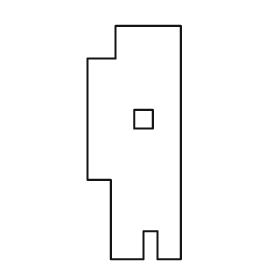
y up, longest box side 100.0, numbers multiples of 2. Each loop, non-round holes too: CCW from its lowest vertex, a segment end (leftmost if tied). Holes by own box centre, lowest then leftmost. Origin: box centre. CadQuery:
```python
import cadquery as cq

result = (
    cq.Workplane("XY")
    .moveTo(-10.0, -50.0)
    .lineTo(4.0, -50.0)
    .lineTo(4.0, -38.0)
    .lineTo(10.0, -38.0)
    .lineTo(10.0, -50.0)
    .lineTo(20.0, -50.0)
    .lineTo(20.0, 50.0)
    .lineTo(-8.0, 50.0)
    .lineTo(-8.0, 36.0)
    .lineTo(-20.0, 36.0)
    .lineTo(-20.0, -16.0)
    .lineTo(-10.0, -16.0)
    .close()
    .moveTo(0.0, 6.0)
    .lineTo(8.0, 6.0)
    .lineTo(8.0, 14.0)
    .lineTo(0.0, 14.0)
    .close()
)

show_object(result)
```